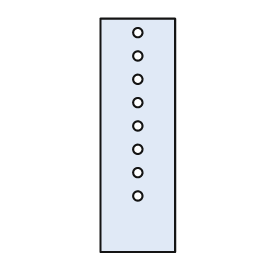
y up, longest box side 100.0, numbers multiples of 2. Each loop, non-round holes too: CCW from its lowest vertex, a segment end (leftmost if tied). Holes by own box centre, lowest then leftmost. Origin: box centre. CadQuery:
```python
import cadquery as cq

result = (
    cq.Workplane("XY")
    .moveTo(-16.0, -50.0)
    .lineTo(16.0, -50.0)
    .lineTo(16.0, 50.0)
    .lineTo(-16.0, 50.0)
    .close()
    .moveTo(0.0, -26.0)
    .circle(2.0)
    .moveTo(0.0, -16.0)
    .circle(2.0)
    .moveTo(0.0, -6.0)
    .circle(2.0)
    .moveTo(0.0, 4.0)
    .circle(2.0)
    .moveTo(0.0, 14.0)
    .circle(2.0)
    .moveTo(0.0, 24.0)
    .circle(2.0)
    .moveTo(0.0, 34.0)
    .circle(2.0)
    .moveTo(0.0, 44.0)
    .circle(2.0)
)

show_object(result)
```